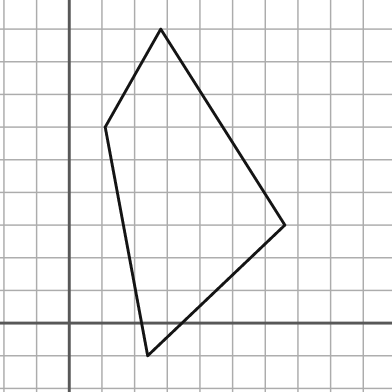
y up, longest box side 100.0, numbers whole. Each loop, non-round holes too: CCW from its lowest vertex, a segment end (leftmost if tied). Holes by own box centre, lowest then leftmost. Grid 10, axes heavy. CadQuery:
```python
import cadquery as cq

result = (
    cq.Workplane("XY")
    .moveTo(24.0, -10.0)
    .lineTo(66.0, 30.0)
    .lineTo(28.0, 90.0)
    .lineTo(11.0, 60.0)
    .close()
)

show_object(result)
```